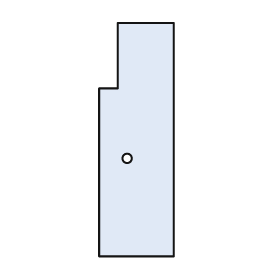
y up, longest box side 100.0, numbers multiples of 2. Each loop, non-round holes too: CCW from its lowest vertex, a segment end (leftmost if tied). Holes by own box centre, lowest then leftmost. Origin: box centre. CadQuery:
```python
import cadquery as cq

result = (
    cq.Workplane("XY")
    .moveTo(-16.0, -50.0)
    .lineTo(16.0, -50.0)
    .lineTo(16.0, 50.0)
    .lineTo(-8.0, 50.0)
    .lineTo(-8.0, 22.0)
    .lineTo(-16.0, 22.0)
    .close()
    .moveTo(-4.0, -8.0)
    .circle(2.0)
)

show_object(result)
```